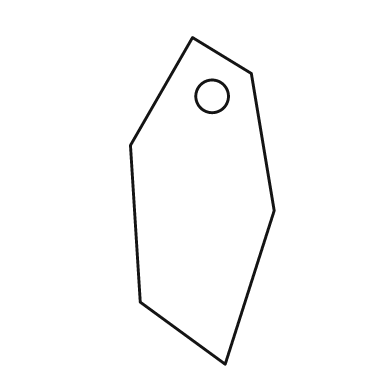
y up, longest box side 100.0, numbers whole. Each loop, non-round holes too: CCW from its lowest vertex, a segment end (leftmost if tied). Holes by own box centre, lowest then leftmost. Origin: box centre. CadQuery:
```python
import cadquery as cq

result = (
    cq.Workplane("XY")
    .moveTo(7.0, -50.0)
    .lineTo(22.0, -3.0)
    .lineTo(15.0, 39.0)
    .lineTo(-3.0, 50.0)
    .lineTo(-22.0, 17.0)
    .lineTo(-19.0, -31.0)
    .close()
    .moveTo(3.0, 32.0)
    .circle(5.0)
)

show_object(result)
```